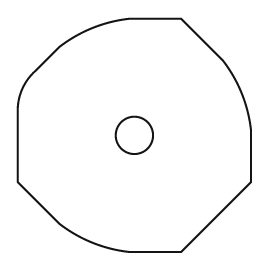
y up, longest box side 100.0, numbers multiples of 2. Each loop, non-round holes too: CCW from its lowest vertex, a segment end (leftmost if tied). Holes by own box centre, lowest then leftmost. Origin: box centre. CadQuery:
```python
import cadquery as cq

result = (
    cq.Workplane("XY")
    .moveTo(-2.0, -50.0)
    .lineTo(20.0, -50.0)
    .lineTo(50.0, -20.0)
    .lineTo(50.0, 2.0)
    .threePointArc((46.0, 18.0), (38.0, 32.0))
    .lineTo(20.0, 50.0)
    .lineTo(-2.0, 50.0)
    .threePointArc((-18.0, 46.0), (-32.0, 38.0))
    .lineTo(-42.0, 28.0)
    .threePointArc((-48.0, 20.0), (-50.0, 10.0))
    .lineTo(-50.0, -20.0)
    .lineTo(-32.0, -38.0)
    .threePointArc((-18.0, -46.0), (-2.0, -50.0))
    .close()
    .moveTo(0.0, 0.0)
    .circle(8.0)
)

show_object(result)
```